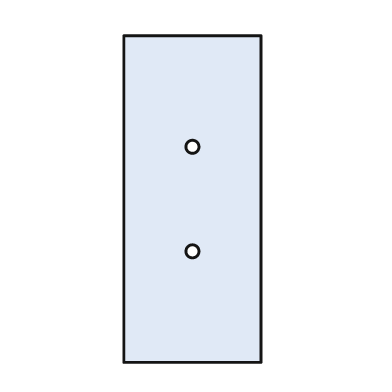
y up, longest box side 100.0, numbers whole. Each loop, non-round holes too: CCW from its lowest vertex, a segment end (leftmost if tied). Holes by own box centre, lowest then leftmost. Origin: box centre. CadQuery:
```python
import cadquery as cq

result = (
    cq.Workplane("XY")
    .moveTo(-21.0, -50.0)
    .lineTo(21.0, -50.0)
    .lineTo(21.0, 50.0)
    .lineTo(-21.0, 50.0)
    .close()
    .moveTo(0.0, -16.0)
    .circle(2.0)
    .moveTo(0.0, 16.0)
    .circle(2.0)
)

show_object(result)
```